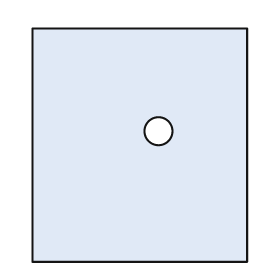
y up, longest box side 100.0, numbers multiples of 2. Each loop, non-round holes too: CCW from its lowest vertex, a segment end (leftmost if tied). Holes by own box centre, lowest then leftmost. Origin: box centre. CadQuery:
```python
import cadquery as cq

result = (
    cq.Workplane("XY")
    .moveTo(-46.0, -50.0)
    .lineTo(46.0, -50.0)
    .lineTo(46.0, 50.0)
    .lineTo(-46.0, 50.0)
    .close()
    .moveTo(8.0, 6.0)
    .circle(6.0)
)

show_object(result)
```